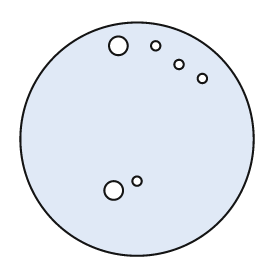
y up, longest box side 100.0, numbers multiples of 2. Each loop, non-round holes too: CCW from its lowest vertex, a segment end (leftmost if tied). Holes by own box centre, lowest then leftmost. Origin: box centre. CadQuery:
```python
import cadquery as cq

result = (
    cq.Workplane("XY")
    .moveTo(0.0, 0.0)
    .circle(50.0)
    .moveTo(-10.0, -22.0)
    .circle(4.0)
    .moveTo(0.0, -18.0)
    .circle(2.0)
    .moveTo(28.0, 26.0)
    .circle(2.0)
    .moveTo(18.0, 32.0)
    .circle(2.0)
    .moveTo(-8.0, 40.0)
    .circle(4.0)
    .moveTo(8.0, 40.0)
    .circle(2.0)
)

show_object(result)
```